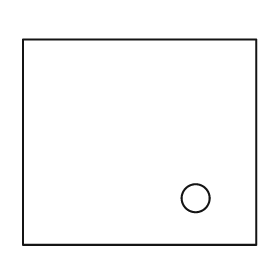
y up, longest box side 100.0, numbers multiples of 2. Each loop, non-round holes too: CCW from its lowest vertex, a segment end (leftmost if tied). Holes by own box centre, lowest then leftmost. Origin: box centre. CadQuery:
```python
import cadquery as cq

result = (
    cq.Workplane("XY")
    .moveTo(-50.0, -44.0)
    .lineTo(50.0, -44.0)
    .lineTo(50.0, 44.0)
    .lineTo(-50.0, 44.0)
    .close()
    .moveTo(24.0, -24.0)
    .circle(6.0)
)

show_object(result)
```